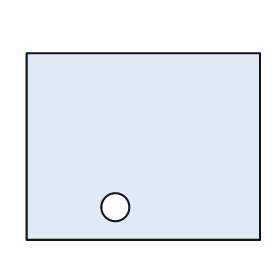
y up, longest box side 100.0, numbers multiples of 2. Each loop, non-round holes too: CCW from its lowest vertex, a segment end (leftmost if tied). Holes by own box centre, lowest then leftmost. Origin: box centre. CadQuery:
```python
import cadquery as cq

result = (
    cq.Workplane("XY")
    .moveTo(-50.0, -40.0)
    .lineTo(50.0, -40.0)
    .lineTo(50.0, 40.0)
    .lineTo(-50.0, 40.0)
    .close()
    .moveTo(-12.0, -26.0)
    .circle(6.0)
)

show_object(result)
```